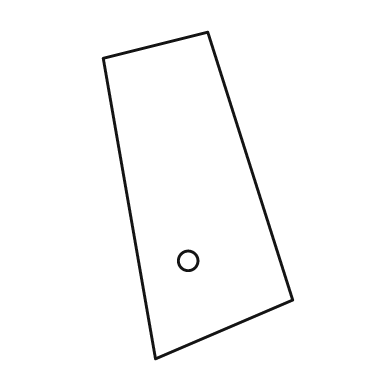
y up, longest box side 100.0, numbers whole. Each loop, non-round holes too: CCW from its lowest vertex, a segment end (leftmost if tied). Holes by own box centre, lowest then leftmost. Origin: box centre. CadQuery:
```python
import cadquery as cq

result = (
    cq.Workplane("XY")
    .moveTo(-13.0, -50.0)
    .lineTo(29.0, -32.0)
    .lineTo(3.0, 50.0)
    .lineTo(-29.0, 42.0)
    .close()
    .moveTo(-3.0, -20.0)
    .circle(3.0)
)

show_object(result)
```